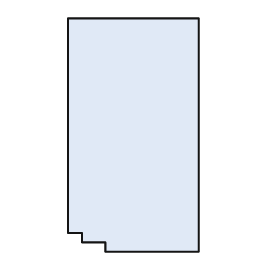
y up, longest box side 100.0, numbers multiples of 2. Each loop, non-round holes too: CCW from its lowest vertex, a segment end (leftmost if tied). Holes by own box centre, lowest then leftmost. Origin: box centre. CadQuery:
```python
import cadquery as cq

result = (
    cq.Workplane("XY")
    .moveTo(-12.0, -50.0)
    .lineTo(28.0, -50.0)
    .lineTo(28.0, 50.0)
    .lineTo(-28.0, 50.0)
    .lineTo(-28.0, -42.0)
    .lineTo(-22.0, -42.0)
    .lineTo(-22.0, -46.0)
    .lineTo(-12.0, -46.0)
    .close()
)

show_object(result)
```